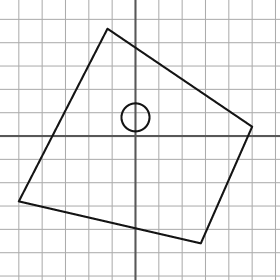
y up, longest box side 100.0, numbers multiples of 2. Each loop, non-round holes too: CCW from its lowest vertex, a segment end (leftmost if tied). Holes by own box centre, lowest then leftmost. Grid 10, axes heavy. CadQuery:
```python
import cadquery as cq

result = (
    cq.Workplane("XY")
    .moveTo(28.0, -46.0)
    .lineTo(50.0, 4.0)
    .lineTo(-12.0, 46.0)
    .lineTo(-50.0, -28.0)
    .close()
    .moveTo(0.0, 8.0)
    .circle(6.0)
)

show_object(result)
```